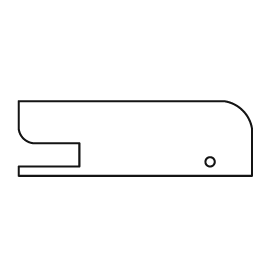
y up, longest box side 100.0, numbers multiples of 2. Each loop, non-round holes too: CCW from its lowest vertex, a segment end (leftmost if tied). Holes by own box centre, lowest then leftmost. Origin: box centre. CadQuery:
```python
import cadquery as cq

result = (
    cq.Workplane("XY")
    .moveTo(-50.0, -16.0)
    .lineTo(50.0, -16.0)
    .lineTo(50.0, 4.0)
    .threePointArc((46.0, 12.0), (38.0, 16.0))
    .lineTo(-50.0, 16.0)
    .lineTo(-50.0, 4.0)
    .threePointArc((-48.0, 0.0), (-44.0, -2.0))
    .lineTo(-24.0, -2.0)
    .lineTo(-24.0, -12.0)
    .lineTo(-50.0, -12.0)
    .close()
    .moveTo(32.0, -10.0)
    .circle(2.0)
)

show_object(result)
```